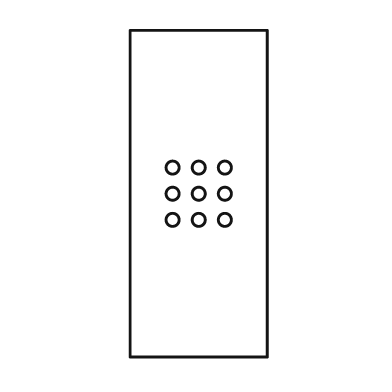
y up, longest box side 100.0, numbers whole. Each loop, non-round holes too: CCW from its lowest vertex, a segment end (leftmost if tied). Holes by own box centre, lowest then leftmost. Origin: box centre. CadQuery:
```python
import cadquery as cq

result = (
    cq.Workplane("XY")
    .moveTo(-21.0, -50.0)
    .lineTo(21.0, -50.0)
    .lineTo(21.0, 50.0)
    .lineTo(-21.0, 50.0)
    .close()
    .moveTo(-8.0, -8.0)
    .circle(2.0)
    .moveTo(0.0, -8.0)
    .circle(2.0)
    .moveTo(8.0, -8.0)
    .circle(2.0)
    .moveTo(-8.0, 0.0)
    .circle(2.0)
    .moveTo(0.0, 0.0)
    .circle(2.0)
    .moveTo(8.0, 0.0)
    .circle(2.0)
    .moveTo(-8.0, 8.0)
    .circle(2.0)
    .moveTo(0.0, 8.0)
    .circle(2.0)
    .moveTo(8.0, 8.0)
    .circle(2.0)
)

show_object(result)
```